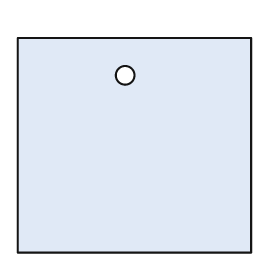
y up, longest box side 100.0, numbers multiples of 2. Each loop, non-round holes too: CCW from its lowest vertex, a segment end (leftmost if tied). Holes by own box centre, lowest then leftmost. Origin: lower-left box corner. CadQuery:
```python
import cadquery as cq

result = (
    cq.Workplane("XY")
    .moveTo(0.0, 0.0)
    .lineTo(100.0, 0.0)
    .lineTo(100.0, 92.0)
    .lineTo(0.0, 92.0)
    .close()
    .moveTo(46.0, 76.0)
    .circle(4.0)
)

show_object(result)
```